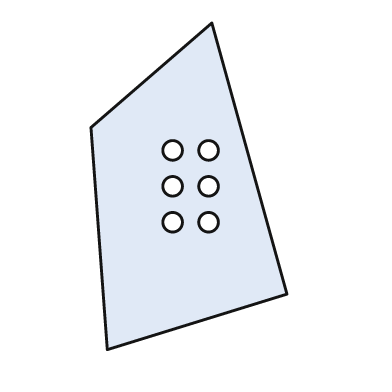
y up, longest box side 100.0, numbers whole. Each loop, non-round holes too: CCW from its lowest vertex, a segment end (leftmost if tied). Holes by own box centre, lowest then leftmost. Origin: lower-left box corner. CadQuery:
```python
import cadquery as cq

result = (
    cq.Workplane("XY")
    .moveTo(5.0, 0.0)
    .lineTo(60.0, 17.0)
    .lineTo(37.0, 100.0)
    .lineTo(0.0, 68.0)
    .close()
    .moveTo(25.0, 39.0)
    .circle(3.0)
    .moveTo(36.0, 39.0)
    .circle(3.0)
    .moveTo(25.0, 50.0)
    .circle(3.0)
    .moveTo(36.0, 50.0)
    .circle(3.0)
    .moveTo(25.0, 61.0)
    .circle(3.0)
    .moveTo(36.0, 61.0)
    .circle(3.0)
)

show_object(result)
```